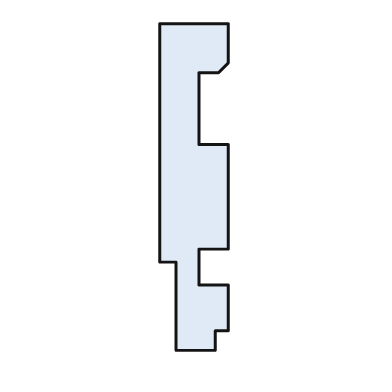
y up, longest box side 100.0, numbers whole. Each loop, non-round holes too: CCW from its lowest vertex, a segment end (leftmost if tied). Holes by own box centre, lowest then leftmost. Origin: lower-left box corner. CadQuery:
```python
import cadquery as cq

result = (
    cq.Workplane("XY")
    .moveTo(5.0, 0.0)
    .lineTo(17.0, 0.0)
    .lineTo(17.0, 6.0)
    .lineTo(21.0, 6.0)
    .lineTo(21.0, 20.0)
    .lineTo(12.0, 20.0)
    .lineTo(12.0, 31.0)
    .lineTo(21.0, 31.0)
    .lineTo(21.0, 63.0)
    .lineTo(12.0, 63.0)
    .lineTo(12.0, 85.0)
    .lineTo(18.0, 85.0)
    .lineTo(21.0, 88.0)
    .lineTo(21.0, 100.0)
    .lineTo(0.0, 100.0)
    .lineTo(0.0, 27.0)
    .lineTo(5.0, 27.0)
    .close()
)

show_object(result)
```